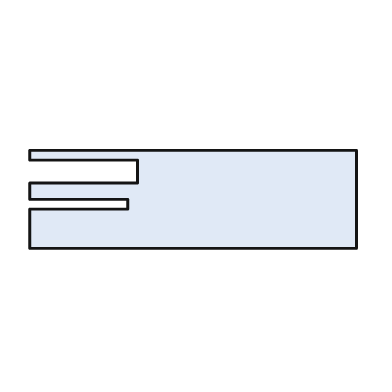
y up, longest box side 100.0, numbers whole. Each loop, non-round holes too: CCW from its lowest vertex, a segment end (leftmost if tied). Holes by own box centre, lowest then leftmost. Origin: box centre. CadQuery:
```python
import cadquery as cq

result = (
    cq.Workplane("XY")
    .moveTo(-50.0, -15.0)
    .lineTo(50.0, -15.0)
    .lineTo(50.0, 15.0)
    .lineTo(-50.0, 15.0)
    .lineTo(-50.0, 12.0)
    .lineTo(-17.0, 12.0)
    .lineTo(-17.0, 5.0)
    .lineTo(-50.0, 5.0)
    .lineTo(-50.0, 0.0)
    .lineTo(-20.0, 0.0)
    .lineTo(-20.0, -3.0)
    .lineTo(-50.0, -3.0)
    .close()
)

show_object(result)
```